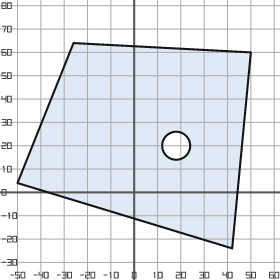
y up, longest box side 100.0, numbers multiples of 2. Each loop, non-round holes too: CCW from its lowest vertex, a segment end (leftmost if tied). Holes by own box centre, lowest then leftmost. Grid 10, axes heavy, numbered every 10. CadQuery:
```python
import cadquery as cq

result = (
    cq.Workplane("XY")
    .moveTo(42.0, -24.0)
    .lineTo(50.0, 60.0)
    .lineTo(-26.0, 64.0)
    .lineTo(-50.0, 4.0)
    .close()
    .moveTo(18.0, 20.0)
    .circle(6.0)
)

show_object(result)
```